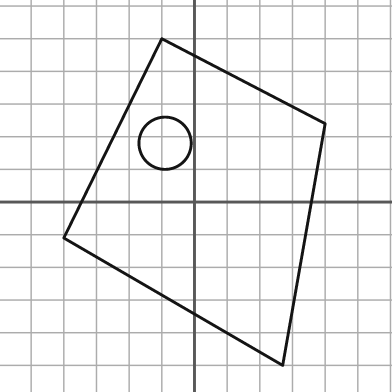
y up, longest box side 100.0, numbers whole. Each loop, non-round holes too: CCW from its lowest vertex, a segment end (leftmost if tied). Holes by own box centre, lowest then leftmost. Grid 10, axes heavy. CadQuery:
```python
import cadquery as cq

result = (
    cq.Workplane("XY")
    .moveTo(27.0, -50.0)
    .lineTo(40.0, 24.0)
    .lineTo(-10.0, 50.0)
    .lineTo(-40.0, -11.0)
    .close()
    .moveTo(-9.0, 18.0)
    .circle(8.0)
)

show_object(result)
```